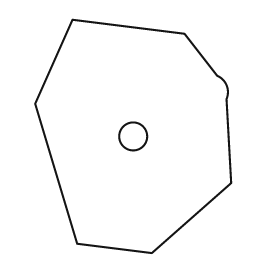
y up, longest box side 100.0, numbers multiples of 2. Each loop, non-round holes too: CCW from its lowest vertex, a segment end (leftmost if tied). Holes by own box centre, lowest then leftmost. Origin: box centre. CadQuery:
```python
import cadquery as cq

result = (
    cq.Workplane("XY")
    .moveTo(8.0, -50.0)
    .lineTo(42.0, -20.0)
    .lineTo(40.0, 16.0)
    .threePointArc((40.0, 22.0), (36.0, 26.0))
    .lineTo(22.0, 44.0)
    .lineTo(-26.0, 50.0)
    .lineTo(-42.0, 14.0)
    .lineTo(-24.0, -46.0)
    .close()
    .moveTo(0.0, 0.0)
    .circle(6.0)
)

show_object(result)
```